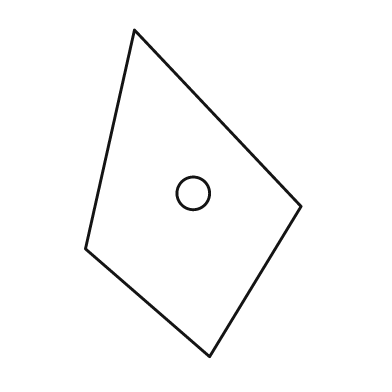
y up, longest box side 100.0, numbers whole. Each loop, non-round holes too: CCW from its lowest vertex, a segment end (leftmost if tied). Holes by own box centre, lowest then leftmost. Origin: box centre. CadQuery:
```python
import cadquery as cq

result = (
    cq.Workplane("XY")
    .moveTo(5.0, -50.0)
    .lineTo(33.0, -4.0)
    .lineTo(-18.0, 50.0)
    .lineTo(-33.0, -17.0)
    .close()
    .moveTo(0.0, 0.0)
    .circle(5.0)
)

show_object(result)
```